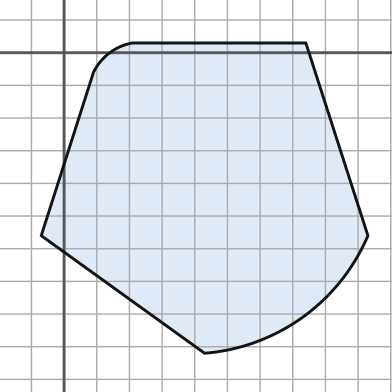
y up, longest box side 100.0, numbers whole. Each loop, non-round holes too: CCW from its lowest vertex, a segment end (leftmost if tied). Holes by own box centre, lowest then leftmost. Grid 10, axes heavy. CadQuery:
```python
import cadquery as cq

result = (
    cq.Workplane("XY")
    .moveTo(43.0, -92.0)
    .threePointArc((73.0, -81.0), (93.0, -56.0))
    .lineTo(74.0, 3.0)
    .lineTo(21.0, 3.0)
    .threePointArc((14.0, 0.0), (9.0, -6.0))
    .lineTo(-7.0, -56.0)
    .close()
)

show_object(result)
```